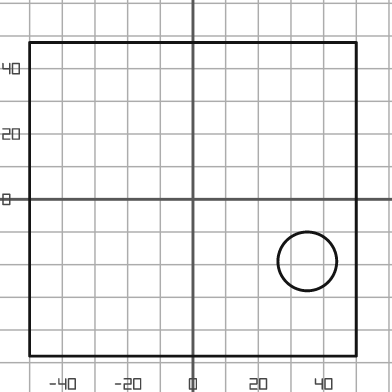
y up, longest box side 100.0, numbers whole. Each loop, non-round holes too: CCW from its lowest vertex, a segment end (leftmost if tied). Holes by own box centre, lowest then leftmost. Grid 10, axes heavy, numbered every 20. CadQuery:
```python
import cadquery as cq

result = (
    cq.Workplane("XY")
    .moveTo(-50.0, -48.0)
    .lineTo(50.0, -48.0)
    .lineTo(50.0, 48.0)
    .lineTo(-50.0, 48.0)
    .close()
    .moveTo(35.0, -19.0)
    .circle(9.0)
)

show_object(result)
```